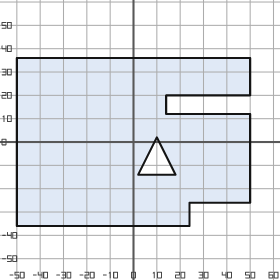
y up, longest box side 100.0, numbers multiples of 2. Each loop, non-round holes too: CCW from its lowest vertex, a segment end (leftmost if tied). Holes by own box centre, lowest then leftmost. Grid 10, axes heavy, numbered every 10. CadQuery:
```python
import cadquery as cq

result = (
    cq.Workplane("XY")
    .moveTo(-50.0, -36.0)
    .lineTo(24.0, -36.0)
    .lineTo(24.0, -26.0)
    .lineTo(50.0, -26.0)
    .lineTo(50.0, 12.0)
    .lineTo(14.0, 12.0)
    .lineTo(14.0, 20.0)
    .lineTo(50.0, 20.0)
    .lineTo(50.0, 36.0)
    .lineTo(-50.0, 36.0)
    .close()
    .moveTo(2.0, -14.0)
    .lineTo(18.0, -14.0)
    .lineTo(10.0, 2.0)
    .close()
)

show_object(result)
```